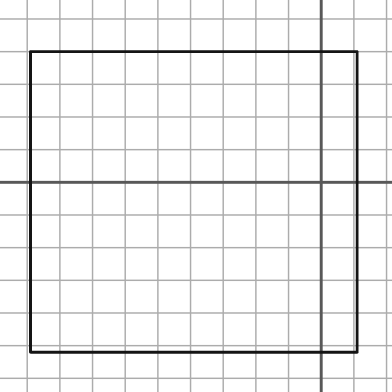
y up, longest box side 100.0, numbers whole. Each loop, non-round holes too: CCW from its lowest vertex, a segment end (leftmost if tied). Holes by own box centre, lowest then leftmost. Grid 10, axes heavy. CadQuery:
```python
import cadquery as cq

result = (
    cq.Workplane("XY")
    .moveTo(-89.0, -52.0)
    .lineTo(11.0, -52.0)
    .lineTo(11.0, 40.0)
    .lineTo(-89.0, 40.0)
    .close()
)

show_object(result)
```